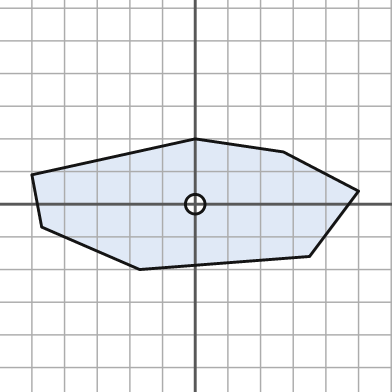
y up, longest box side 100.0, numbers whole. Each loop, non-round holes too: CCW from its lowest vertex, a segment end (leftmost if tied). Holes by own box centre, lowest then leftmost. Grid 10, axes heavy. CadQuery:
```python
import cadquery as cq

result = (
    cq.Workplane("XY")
    .moveTo(-17.0, -20.0)
    .lineTo(35.0, -16.0)
    .lineTo(50.0, 4.0)
    .lineTo(27.0, 16.0)
    .lineTo(0.0, 20.0)
    .lineTo(-50.0, 9.0)
    .lineTo(-47.0, -7.0)
    .close()
    .moveTo(0.0, 0.0)
    .circle(3.0)
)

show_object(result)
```